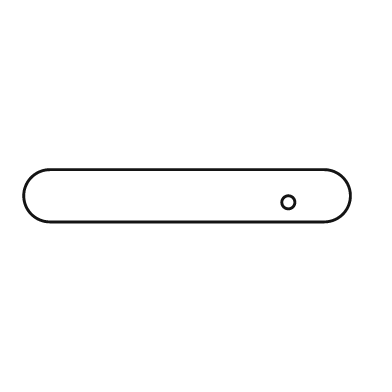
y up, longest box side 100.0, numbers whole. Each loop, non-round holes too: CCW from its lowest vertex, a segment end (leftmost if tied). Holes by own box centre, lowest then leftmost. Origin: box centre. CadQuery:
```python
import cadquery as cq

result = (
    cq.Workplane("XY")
    .moveTo(-42.0, -8.0)
    .lineTo(42.0, -8.0)
    .threePointArc((50.0, 0.0), (42.0, 8.0))
    .lineTo(-42.0, 8.0)
    .threePointArc((-50.0, 0.0), (-42.0, -8.0))
    .close()
    .moveTo(31.0, -2.0)
    .circle(2.0)
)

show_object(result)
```